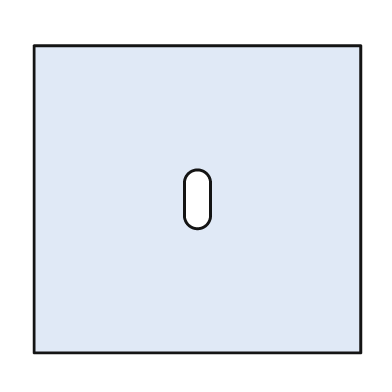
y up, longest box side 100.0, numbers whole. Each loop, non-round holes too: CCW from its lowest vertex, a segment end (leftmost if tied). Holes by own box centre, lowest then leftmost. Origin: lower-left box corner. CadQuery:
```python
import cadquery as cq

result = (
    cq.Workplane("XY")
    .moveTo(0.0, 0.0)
    .lineTo(100.0, 0.0)
    .lineTo(100.0, 94.0)
    .lineTo(0.0, 94.0)
    .close()
    .moveTo(46.0, 42.0)
    .threePointArc((50.0, 38.0), (54.0, 42.0))
    .lineTo(54.0, 52.0)
    .threePointArc((50.0, 56.0), (46.0, 52.0))
    .close()
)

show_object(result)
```